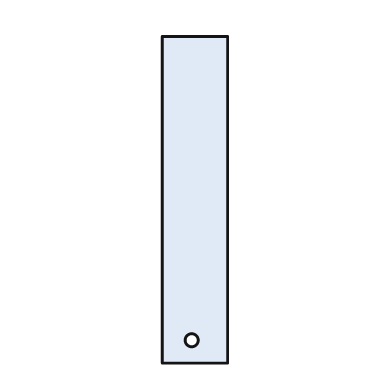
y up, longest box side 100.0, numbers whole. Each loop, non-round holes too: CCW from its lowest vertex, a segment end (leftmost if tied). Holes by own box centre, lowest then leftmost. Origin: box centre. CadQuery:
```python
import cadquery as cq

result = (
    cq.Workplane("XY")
    .moveTo(-10.0, -50.0)
    .lineTo(10.0, -50.0)
    .lineTo(10.0, 50.0)
    .lineTo(-10.0, 50.0)
    .close()
    .moveTo(-1.0, -43.0)
    .circle(2.0)
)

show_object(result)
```